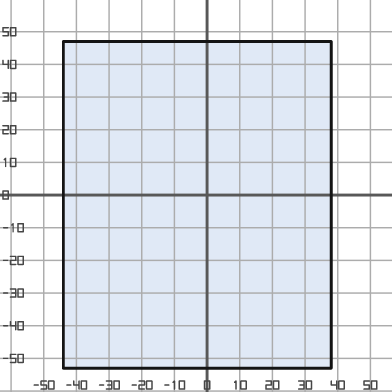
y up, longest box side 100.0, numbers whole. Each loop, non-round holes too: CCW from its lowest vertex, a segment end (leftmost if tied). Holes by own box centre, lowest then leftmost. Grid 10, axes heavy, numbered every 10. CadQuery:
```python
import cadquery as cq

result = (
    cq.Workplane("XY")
    .moveTo(-44.0, -53.0)
    .lineTo(38.0, -53.0)
    .lineTo(38.0, 47.0)
    .lineTo(-44.0, 47.0)
    .close()
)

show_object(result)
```